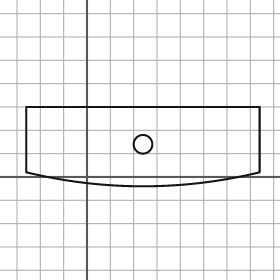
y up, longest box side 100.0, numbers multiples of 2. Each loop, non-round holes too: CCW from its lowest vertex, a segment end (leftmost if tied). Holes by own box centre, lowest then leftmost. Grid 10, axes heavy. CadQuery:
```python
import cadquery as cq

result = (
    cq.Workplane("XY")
    .moveTo(-26.0, 2.0)
    .threePointArc((24.0, -4.0), (74.0, 2.0))
    .lineTo(74.0, 30.0)
    .lineTo(-26.0, 30.0)
    .close()
    .moveTo(24.0, 14.0)
    .circle(4.0)
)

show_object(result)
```